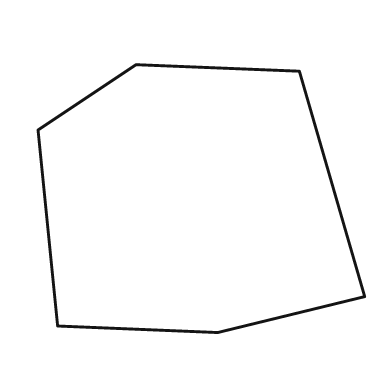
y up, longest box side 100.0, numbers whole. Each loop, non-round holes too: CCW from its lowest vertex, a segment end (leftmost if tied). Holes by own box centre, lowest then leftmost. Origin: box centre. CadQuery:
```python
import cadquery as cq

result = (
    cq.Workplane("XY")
    .moveTo(5.0, -41.0)
    .lineTo(50.0, -30.0)
    .lineTo(30.0, 39.0)
    .lineTo(-20.0, 41.0)
    .lineTo(-50.0, 21.0)
    .lineTo(-44.0, -39.0)
    .close()
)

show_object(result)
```